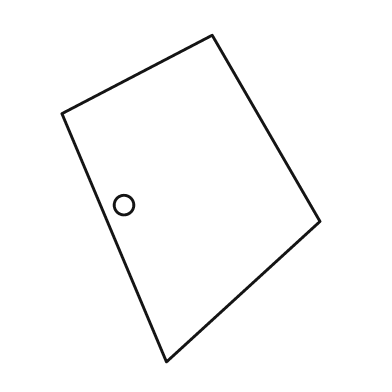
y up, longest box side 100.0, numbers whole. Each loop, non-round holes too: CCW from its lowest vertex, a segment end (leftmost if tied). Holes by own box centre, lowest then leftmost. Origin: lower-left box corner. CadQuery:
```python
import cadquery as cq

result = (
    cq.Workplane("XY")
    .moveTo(32.0, 0.0)
    .lineTo(79.0, 43.0)
    .lineTo(46.0, 100.0)
    .lineTo(0.0, 76.0)
    .close()
    .moveTo(19.0, 48.0)
    .circle(3.0)
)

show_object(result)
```